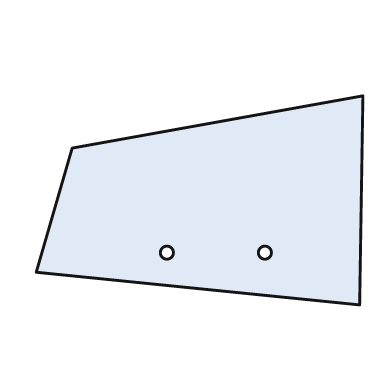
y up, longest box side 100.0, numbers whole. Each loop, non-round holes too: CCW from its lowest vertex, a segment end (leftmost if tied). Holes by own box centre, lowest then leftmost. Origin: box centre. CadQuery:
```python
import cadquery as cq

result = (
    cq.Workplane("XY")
    .moveTo(49.0, -32.0)
    .lineTo(50.0, 32.0)
    .lineTo(-39.0, 16.0)
    .lineTo(-50.0, -22.0)
    .close()
    .moveTo(-10.0, -16.0)
    .circle(2.0)
    .moveTo(20.0, -16.0)
    .circle(2.0)
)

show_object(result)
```